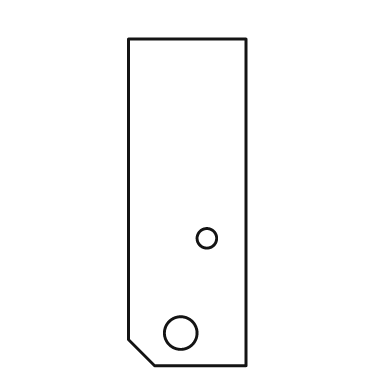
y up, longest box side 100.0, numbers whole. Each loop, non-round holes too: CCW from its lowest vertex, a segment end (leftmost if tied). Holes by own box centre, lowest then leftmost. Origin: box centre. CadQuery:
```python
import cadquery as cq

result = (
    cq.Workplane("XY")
    .moveTo(-10.0, -50.0)
    .lineTo(18.0, -50.0)
    .lineTo(18.0, 50.0)
    .lineTo(-18.0, 50.0)
    .lineTo(-18.0, -42.0)
    .close()
    .moveTo(-2.0, -40.0)
    .circle(5.0)
    .moveTo(6.0, -11.0)
    .circle(3.0)
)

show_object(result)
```